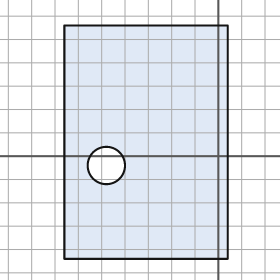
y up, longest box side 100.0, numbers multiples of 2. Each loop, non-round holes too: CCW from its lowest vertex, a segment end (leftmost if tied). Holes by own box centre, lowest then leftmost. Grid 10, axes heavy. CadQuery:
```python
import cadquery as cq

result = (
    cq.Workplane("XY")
    .moveTo(-66.0, -44.0)
    .lineTo(4.0, -44.0)
    .lineTo(4.0, 56.0)
    .lineTo(-66.0, 56.0)
    .close()
    .moveTo(-48.0, -4.0)
    .circle(8.0)
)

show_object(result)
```